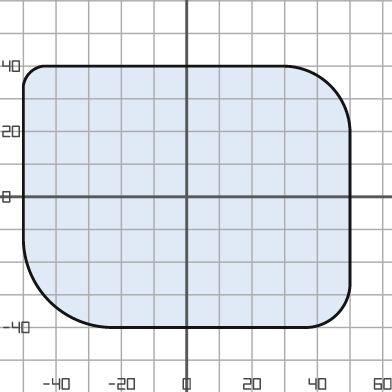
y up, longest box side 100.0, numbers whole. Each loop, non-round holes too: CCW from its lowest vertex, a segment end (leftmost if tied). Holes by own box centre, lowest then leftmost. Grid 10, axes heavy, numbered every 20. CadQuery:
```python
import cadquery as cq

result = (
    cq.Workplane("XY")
    .moveTo(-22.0, -40.0)
    .lineTo(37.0, -40.0)
    .threePointArc((46.0, -36.0), (50.0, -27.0))
    .lineTo(50.0, 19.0)
    .threePointArc((44.0, 34.0), (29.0, 40.0))
    .lineTo(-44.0, 40.0)
    .threePointArc((-48.0, 38.0), (-50.0, 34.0))
    .lineTo(-50.0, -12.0)
    .threePointArc((-42.0, -32.0), (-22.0, -40.0))
    .close()
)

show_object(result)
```